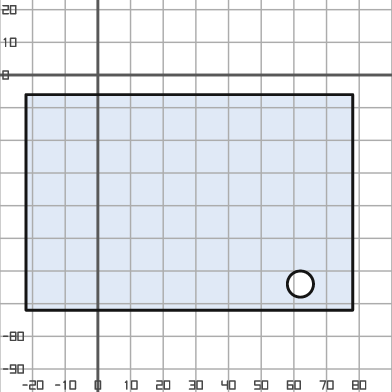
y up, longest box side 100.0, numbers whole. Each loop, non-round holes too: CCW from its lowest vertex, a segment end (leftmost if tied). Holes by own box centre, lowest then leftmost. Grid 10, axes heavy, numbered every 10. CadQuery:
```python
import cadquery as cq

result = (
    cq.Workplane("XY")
    .moveTo(-22.0, -72.0)
    .lineTo(78.0, -72.0)
    .lineTo(78.0, -6.0)
    .lineTo(-22.0, -6.0)
    .close()
    .moveTo(62.0, -64.0)
    .circle(4.0)
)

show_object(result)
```